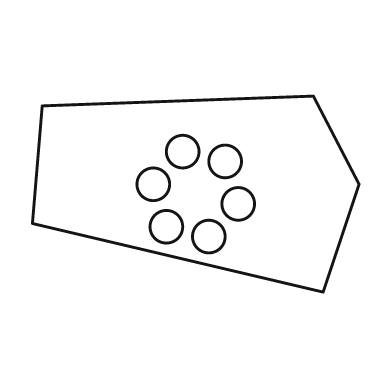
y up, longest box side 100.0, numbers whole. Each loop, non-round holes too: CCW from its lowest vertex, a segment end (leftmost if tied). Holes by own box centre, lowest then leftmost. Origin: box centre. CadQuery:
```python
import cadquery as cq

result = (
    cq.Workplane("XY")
    .moveTo(39.0, -30.0)
    .lineTo(50.0, 3.0)
    .lineTo(36.0, 30.0)
    .lineTo(-47.0, 27.0)
    .lineTo(-50.0, -9.0)
    .close()
    .moveTo(4.0, -13.0)
    .circle(5.0)
    .moveTo(-9.0, -10.0)
    .circle(5.0)
    .moveTo(13.0, -3.0)
    .circle(5.0)
    .moveTo(-13.0, 3.0)
    .circle(5.0)
    .moveTo(9.0, 10.0)
    .circle(5.0)
    .moveTo(-4.0, 13.0)
    .circle(5.0)
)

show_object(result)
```